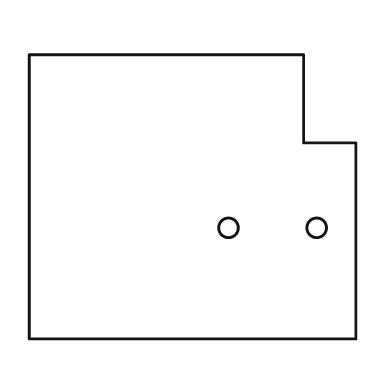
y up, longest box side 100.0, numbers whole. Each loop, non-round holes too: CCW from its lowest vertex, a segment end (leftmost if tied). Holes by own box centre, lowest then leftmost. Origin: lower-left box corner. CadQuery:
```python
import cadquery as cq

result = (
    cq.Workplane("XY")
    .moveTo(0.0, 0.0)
    .lineTo(100.0, 0.0)
    .lineTo(100.0, 60.0)
    .lineTo(84.0, 60.0)
    .lineTo(84.0, 87.0)
    .lineTo(0.0, 87.0)
    .close()
    .moveTo(61.0, 34.0)
    .circle(3.0)
    .moveTo(88.0, 34.0)
    .circle(3.0)
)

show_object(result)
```